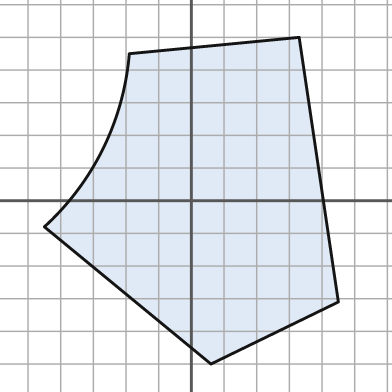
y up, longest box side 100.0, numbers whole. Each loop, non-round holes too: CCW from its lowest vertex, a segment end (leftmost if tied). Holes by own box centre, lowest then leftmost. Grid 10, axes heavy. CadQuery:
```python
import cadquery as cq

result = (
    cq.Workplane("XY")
    .moveTo(6.0, -50.0)
    .lineTo(45.0, -31.0)
    .lineTo(33.0, 50.0)
    .lineTo(-19.0, 45.0)
    .threePointArc((-27.0, 16.0), (-45.0, -8.0))
    .close()
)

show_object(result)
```